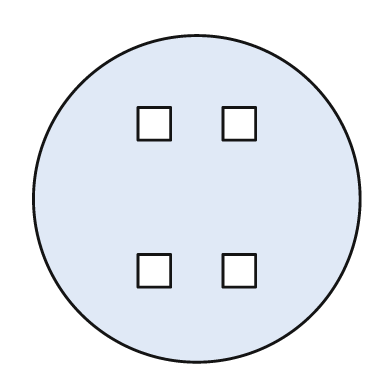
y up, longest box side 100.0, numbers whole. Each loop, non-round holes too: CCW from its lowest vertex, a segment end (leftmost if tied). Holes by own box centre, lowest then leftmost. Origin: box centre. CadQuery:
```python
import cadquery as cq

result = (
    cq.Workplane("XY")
    .moveTo(0.0, 0.0)
    .circle(50.0)
    .moveTo(-18.0, -27.0)
    .lineTo(-8.0, -27.0)
    .lineTo(-8.0, -17.0)
    .lineTo(-18.0, -17.0)
    .close()
    .moveTo(8.0, -27.0)
    .lineTo(18.0, -27.0)
    .lineTo(18.0, -17.0)
    .lineTo(8.0, -17.0)
    .close()
    .moveTo(-18.0, 18.0)
    .lineTo(-8.0, 18.0)
    .lineTo(-8.0, 28.0)
    .lineTo(-18.0, 28.0)
    .close()
    .moveTo(8.0, 18.0)
    .lineTo(18.0, 18.0)
    .lineTo(18.0, 28.0)
    .lineTo(8.0, 28.0)
    .close()
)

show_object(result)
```